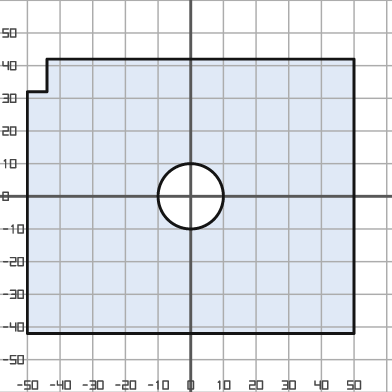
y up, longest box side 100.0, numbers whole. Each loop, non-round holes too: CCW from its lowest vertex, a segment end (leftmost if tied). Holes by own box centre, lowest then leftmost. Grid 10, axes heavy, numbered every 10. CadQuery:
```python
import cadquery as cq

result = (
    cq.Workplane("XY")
    .moveTo(-50.0, -42.0)
    .lineTo(50.0, -42.0)
    .lineTo(50.0, 42.0)
    .lineTo(-44.0, 42.0)
    .lineTo(-44.0, 32.0)
    .lineTo(-50.0, 32.0)
    .close()
    .moveTo(0.0, 0.0)
    .circle(10.0)
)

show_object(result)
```